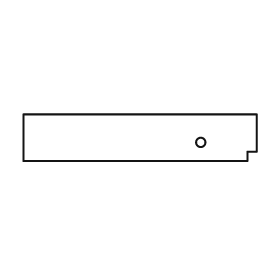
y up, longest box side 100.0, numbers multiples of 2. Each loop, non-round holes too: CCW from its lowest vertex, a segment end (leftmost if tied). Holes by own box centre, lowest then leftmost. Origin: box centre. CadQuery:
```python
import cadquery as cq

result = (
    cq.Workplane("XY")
    .moveTo(-50.0, -10.0)
    .lineTo(46.0, -10.0)
    .lineTo(46.0, -6.0)
    .lineTo(50.0, -6.0)
    .lineTo(50.0, 10.0)
    .lineTo(-50.0, 10.0)
    .close()
    .moveTo(26.0, -2.0)
    .circle(2.0)
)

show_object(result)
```